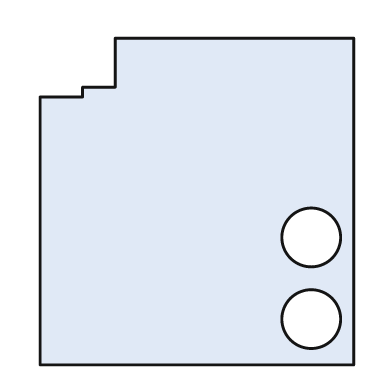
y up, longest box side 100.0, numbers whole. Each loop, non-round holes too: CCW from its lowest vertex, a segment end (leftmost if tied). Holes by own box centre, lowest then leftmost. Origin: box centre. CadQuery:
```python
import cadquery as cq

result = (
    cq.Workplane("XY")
    .moveTo(-48.0, -50.0)
    .lineTo(48.0, -50.0)
    .lineTo(48.0, 50.0)
    .lineTo(-25.0, 50.0)
    .lineTo(-25.0, 35.0)
    .lineTo(-35.0, 35.0)
    .lineTo(-35.0, 32.0)
    .lineTo(-48.0, 32.0)
    .close()
    .moveTo(35.0, -36.0)
    .circle(9.0)
    .moveTo(35.0, -11.0)
    .circle(9.0)
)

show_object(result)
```